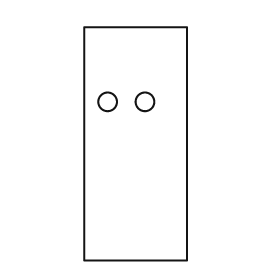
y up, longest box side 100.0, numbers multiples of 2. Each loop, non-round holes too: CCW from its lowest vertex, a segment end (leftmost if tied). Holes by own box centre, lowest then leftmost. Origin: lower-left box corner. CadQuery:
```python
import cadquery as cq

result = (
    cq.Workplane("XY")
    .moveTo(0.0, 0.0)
    .lineTo(44.0, 0.0)
    .lineTo(44.0, 100.0)
    .lineTo(0.0, 100.0)
    .close()
    .moveTo(10.0, 68.0)
    .circle(4.0)
    .moveTo(26.0, 68.0)
    .circle(4.0)
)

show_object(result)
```